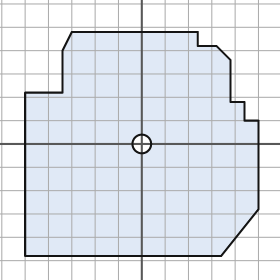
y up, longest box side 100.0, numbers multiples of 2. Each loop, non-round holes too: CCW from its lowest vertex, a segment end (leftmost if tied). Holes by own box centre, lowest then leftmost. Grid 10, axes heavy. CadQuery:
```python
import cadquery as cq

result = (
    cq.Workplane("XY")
    .moveTo(-50.0, -48.0)
    .lineTo(34.0, -48.0)
    .lineTo(50.0, -28.0)
    .lineTo(50.0, 10.0)
    .lineTo(44.0, 10.0)
    .lineTo(44.0, 18.0)
    .lineTo(38.0, 18.0)
    .lineTo(38.0, 36.0)
    .lineTo(32.0, 42.0)
    .lineTo(24.0, 42.0)
    .lineTo(24.0, 48.0)
    .lineTo(-30.0, 48.0)
    .lineTo(-34.0, 40.0)
    .lineTo(-34.0, 22.0)
    .lineTo(-50.0, 22.0)
    .close()
    .moveTo(0.0, 0.0)
    .circle(4.0)
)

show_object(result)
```